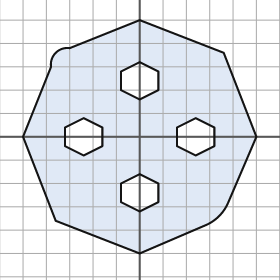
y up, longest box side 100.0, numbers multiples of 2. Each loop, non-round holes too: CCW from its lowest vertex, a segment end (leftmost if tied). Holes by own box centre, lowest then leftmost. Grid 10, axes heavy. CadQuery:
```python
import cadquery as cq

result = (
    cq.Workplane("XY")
    .moveTo(0.0, -50.0)
    .lineTo(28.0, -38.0)
    .threePointArc((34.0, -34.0), (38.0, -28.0))
    .lineTo(50.0, 0.0)
    .lineTo(36.0, 36.0)
    .lineTo(0.0, 50.0)
    .lineTo(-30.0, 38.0)
    .threePointArc((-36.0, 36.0), (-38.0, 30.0))
    .lineTo(-50.0, 0.0)
    .lineTo(-36.0, -36.0)
    .close()
    .moveTo(0.0, -32.0)
    .lineTo(8.0, -28.0)
    .lineTo(8.0, -20.0)
    .lineTo(0.0, -16.0)
    .lineTo(-8.0, -20.0)
    .lineTo(-8.0, -28.0)
    .close()
    .moveTo(-24.0, -8.0)
    .lineTo(-16.0, -4.0)
    .lineTo(-16.0, 4.0)
    .lineTo(-24.0, 8.0)
    .lineTo(-32.0, 4.0)
    .lineTo(-32.0, -4.0)
    .close()
    .moveTo(24.0, -8.0)
    .lineTo(32.0, -4.0)
    .lineTo(32.0, 4.0)
    .lineTo(24.0, 8.0)
    .lineTo(16.0, 4.0)
    .lineTo(16.0, -4.0)
    .close()
    .moveTo(0.0, 16.0)
    .lineTo(8.0, 20.0)
    .lineTo(8.0, 28.0)
    .lineTo(0.0, 32.0)
    .lineTo(-8.0, 28.0)
    .lineTo(-8.0, 20.0)
    .close()
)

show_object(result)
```